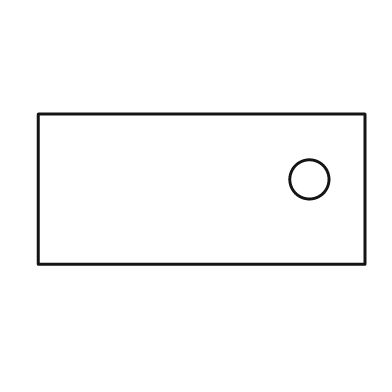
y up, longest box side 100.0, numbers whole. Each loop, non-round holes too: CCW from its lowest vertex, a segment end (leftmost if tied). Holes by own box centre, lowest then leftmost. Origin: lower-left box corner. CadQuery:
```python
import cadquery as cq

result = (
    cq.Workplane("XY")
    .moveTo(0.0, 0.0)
    .lineTo(100.0, 0.0)
    .lineTo(100.0, 46.0)
    .lineTo(0.0, 46.0)
    .close()
    .moveTo(83.0, 26.0)
    .circle(6.0)
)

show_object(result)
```